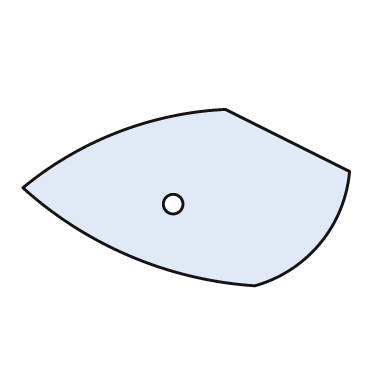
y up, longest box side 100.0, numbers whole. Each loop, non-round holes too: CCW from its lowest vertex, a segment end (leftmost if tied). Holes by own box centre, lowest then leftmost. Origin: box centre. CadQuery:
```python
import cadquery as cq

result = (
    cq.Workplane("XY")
    .moveTo(21.0, -27.0)
    .threePointArc((41.0, -14.0), (50.0, 8.0))
    .lineTo(12.0, 27.0)
    .threePointArc((-21.0, 20.0), (-50.0, 3.0))
    .threePointArc((-17.0, -18.0), (21.0, -27.0))
    .close()
    .moveTo(-4.0, -2.0)
    .circle(3.0)
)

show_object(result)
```